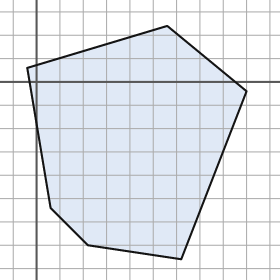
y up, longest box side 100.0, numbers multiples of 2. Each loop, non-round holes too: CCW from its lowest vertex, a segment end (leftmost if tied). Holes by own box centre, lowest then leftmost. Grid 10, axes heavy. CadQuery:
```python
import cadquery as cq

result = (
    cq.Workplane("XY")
    .moveTo(62.0, -76.0)
    .lineTo(90.0, -4.0)
    .lineTo(56.0, 24.0)
    .lineTo(-4.0, 6.0)
    .lineTo(6.0, -54.0)
    .lineTo(22.0, -70.0)
    .close()
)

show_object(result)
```